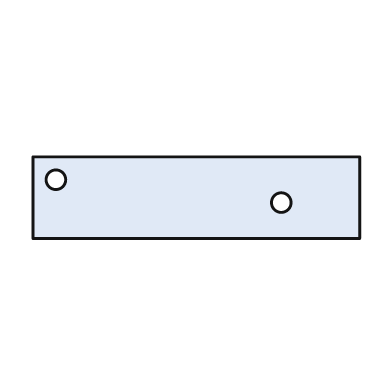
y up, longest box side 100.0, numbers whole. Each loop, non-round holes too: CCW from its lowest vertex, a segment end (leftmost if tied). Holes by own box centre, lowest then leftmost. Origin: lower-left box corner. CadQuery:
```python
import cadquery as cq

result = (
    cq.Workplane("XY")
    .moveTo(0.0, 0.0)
    .lineTo(100.0, 0.0)
    .lineTo(100.0, 25.0)
    .lineTo(0.0, 25.0)
    .close()
    .moveTo(76.0, 11.0)
    .circle(3.0)
    .moveTo(7.0, 18.0)
    .circle(3.0)
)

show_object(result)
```